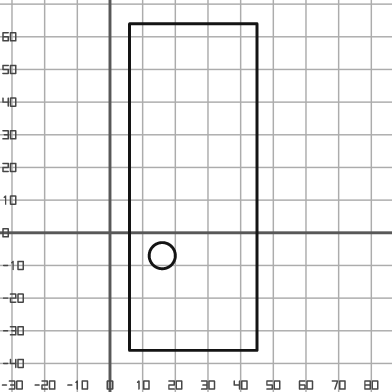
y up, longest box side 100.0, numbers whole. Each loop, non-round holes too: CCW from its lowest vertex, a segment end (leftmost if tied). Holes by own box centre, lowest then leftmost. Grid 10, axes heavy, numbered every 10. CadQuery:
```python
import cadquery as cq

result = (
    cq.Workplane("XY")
    .moveTo(6.0, -36.0)
    .lineTo(45.0, -36.0)
    .lineTo(45.0, 64.0)
    .lineTo(6.0, 64.0)
    .close()
    .moveTo(16.0, -7.0)
    .circle(4.0)
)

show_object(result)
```